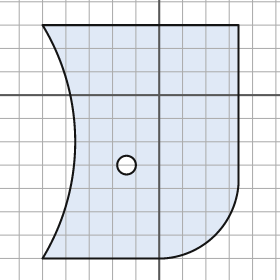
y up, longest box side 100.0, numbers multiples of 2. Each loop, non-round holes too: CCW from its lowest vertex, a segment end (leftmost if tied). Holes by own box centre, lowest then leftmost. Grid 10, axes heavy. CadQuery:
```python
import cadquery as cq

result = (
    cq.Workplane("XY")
    .moveTo(-50.0, -70.0)
    .lineTo(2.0, -70.0)
    .threePointArc((24.0, -60.0), (34.0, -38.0))
    .lineTo(34.0, 30.0)
    .lineTo(-50.0, 30.0)
    .threePointArc((-36.0, -20.0), (-50.0, -70.0))
    .close()
    .moveTo(-14.0, -30.0)
    .circle(4.0)
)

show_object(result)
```